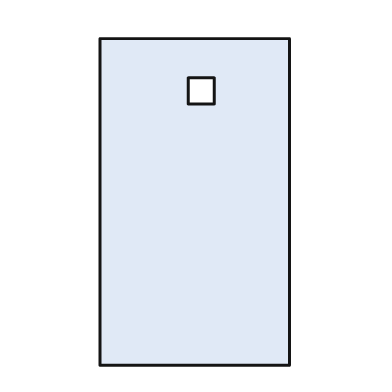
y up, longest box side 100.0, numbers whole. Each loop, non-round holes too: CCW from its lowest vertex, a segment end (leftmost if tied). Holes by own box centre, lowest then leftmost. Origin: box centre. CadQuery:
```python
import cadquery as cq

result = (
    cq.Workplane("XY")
    .moveTo(-29.0, -50.0)
    .lineTo(29.0, -50.0)
    .lineTo(29.0, 50.0)
    .lineTo(-29.0, 50.0)
    .close()
    .moveTo(-2.0, 30.0)
    .lineTo(6.0, 30.0)
    .lineTo(6.0, 38.0)
    .lineTo(-2.0, 38.0)
    .close()
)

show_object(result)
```